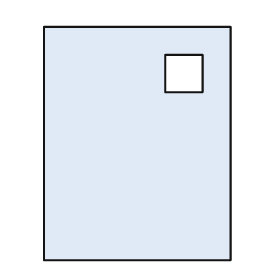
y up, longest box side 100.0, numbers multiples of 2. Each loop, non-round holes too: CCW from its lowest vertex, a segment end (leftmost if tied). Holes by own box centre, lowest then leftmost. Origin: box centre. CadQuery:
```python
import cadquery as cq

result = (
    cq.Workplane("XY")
    .moveTo(-40.0, -50.0)
    .lineTo(40.0, -50.0)
    .lineTo(40.0, 50.0)
    .lineTo(-40.0, 50.0)
    .close()
    .moveTo(12.0, 22.0)
    .lineTo(28.0, 22.0)
    .lineTo(28.0, 38.0)
    .lineTo(12.0, 38.0)
    .close()
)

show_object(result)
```